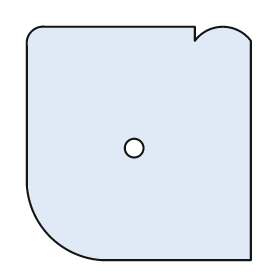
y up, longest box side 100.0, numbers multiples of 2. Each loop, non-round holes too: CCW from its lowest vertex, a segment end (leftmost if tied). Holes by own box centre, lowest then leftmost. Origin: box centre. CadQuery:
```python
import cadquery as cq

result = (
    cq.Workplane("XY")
    .moveTo(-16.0, -50.0)
    .lineTo(48.0, -50.0)
    .lineTo(48.0, 44.0)
    .threePointArc((36.0, 50.0), (24.0, 44.0))
    .lineTo(24.0, 50.0)
    .lineTo(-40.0, 50.0)
    .threePointArc((-46.0, 48.0), (-48.0, 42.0))
    .lineTo(-48.0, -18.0)
    .threePointArc((-38.0, -40.0), (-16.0, -50.0))
    .close()
    .moveTo(-2.0, -2.0)
    .circle(4.0)
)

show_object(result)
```